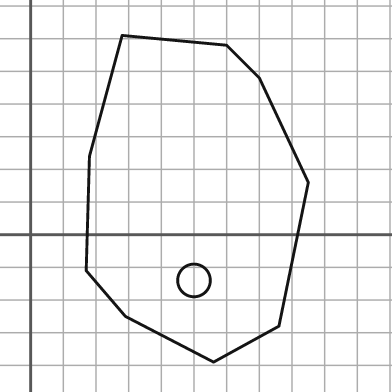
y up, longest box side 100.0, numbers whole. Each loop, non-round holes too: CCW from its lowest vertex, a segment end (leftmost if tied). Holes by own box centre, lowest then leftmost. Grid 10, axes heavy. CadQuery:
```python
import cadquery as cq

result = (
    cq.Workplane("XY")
    .moveTo(56.0, -39.0)
    .lineTo(76.0, -28.0)
    .lineTo(85.0, 16.0)
    .lineTo(70.0, 48.0)
    .lineTo(60.0, 58.0)
    .lineTo(28.0, 61.0)
    .lineTo(18.0, 24.0)
    .lineTo(17.0, -11.0)
    .lineTo(29.0, -25.0)
    .close()
    .moveTo(50.0, -14.0)
    .circle(5.0)
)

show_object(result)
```